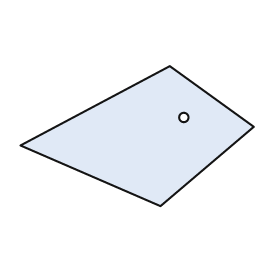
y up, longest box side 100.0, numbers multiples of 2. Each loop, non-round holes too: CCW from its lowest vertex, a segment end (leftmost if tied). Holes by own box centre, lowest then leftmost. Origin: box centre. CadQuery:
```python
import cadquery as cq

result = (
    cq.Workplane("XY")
    .moveTo(10.0, -30.0)
    .lineTo(50.0, 4.0)
    .lineTo(14.0, 30.0)
    .lineTo(-50.0, -4.0)
    .close()
    .moveTo(20.0, 8.0)
    .circle(2.0)
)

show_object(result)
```